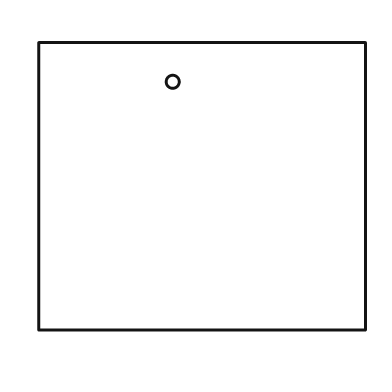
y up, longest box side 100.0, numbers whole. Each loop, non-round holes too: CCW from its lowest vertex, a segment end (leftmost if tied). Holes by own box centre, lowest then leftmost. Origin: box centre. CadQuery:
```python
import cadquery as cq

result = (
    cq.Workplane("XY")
    .moveTo(-50.0, -44.0)
    .lineTo(50.0, -44.0)
    .lineTo(50.0, 44.0)
    .lineTo(-50.0, 44.0)
    .close()
    .moveTo(-9.0, 32.0)
    .circle(2.0)
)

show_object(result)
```